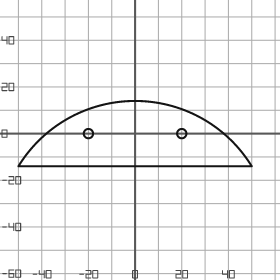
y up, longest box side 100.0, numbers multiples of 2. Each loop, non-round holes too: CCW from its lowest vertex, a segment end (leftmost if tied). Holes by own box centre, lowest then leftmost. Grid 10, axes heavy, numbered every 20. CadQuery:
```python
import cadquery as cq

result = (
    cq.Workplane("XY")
    .moveTo(-50.0, -14.0)
    .lineTo(50.0, -14.0)
    .threePointArc((0.0, 14.0), (-50.0, -14.0))
    .close()
    .moveTo(-20.0, 0.0)
    .circle(2.0)
    .moveTo(20.0, 0.0)
    .circle(2.0)
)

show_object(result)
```